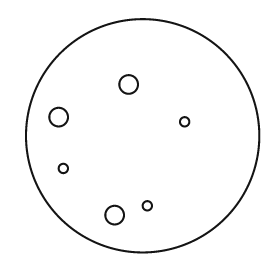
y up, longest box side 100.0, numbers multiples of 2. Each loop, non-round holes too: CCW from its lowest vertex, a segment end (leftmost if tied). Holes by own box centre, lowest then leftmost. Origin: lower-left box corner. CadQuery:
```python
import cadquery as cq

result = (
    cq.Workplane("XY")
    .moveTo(50.0, 50.0)
    .circle(50.0)
    .moveTo(38.0, 16.0)
    .circle(4.0)
    .moveTo(52.0, 20.0)
    .circle(2.0)
    .moveTo(16.0, 36.0)
    .circle(2.0)
    .moveTo(68.0, 56.0)
    .circle(2.0)
    .moveTo(14.0, 58.0)
    .circle(4.0)
    .moveTo(44.0, 72.0)
    .circle(4.0)
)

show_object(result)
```